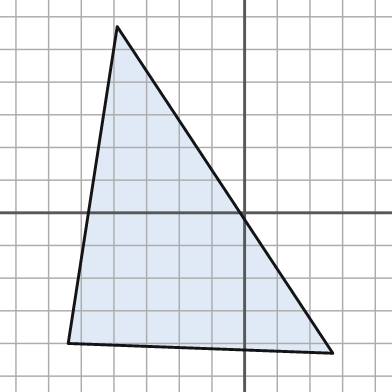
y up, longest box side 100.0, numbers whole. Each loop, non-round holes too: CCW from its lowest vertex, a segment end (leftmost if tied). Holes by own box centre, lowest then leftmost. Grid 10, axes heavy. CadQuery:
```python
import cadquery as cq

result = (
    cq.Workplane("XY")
    .moveTo(27.0, -43.0)
    .lineTo(-39.0, 57.0)
    .lineTo(-54.0, -40.0)
    .close()
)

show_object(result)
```